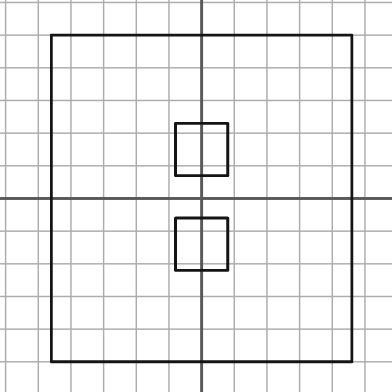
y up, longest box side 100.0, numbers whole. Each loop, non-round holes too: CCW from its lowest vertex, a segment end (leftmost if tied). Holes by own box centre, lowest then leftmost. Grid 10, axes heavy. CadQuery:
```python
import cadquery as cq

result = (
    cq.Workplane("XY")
    .moveTo(-46.0, -50.0)
    .lineTo(46.0, -50.0)
    .lineTo(46.0, 50.0)
    .lineTo(-46.0, 50.0)
    .close()
    .moveTo(-8.0, -22.0)
    .lineTo(8.0, -22.0)
    .lineTo(8.0, -6.0)
    .lineTo(-8.0, -6.0)
    .close()
    .moveTo(-8.0, 7.0)
    .lineTo(8.0, 7.0)
    .lineTo(8.0, 23.0)
    .lineTo(-8.0, 23.0)
    .close()
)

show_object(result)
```